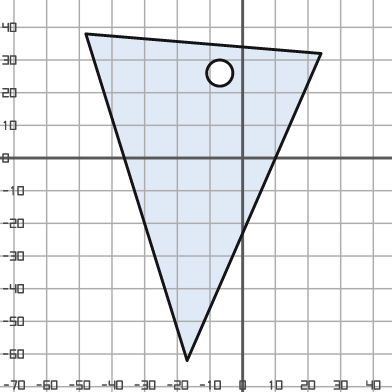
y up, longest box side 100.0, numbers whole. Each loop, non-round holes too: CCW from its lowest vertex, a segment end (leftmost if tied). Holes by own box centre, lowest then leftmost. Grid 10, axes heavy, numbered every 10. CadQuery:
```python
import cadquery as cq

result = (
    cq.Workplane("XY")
    .moveTo(-17.0, -62.0)
    .lineTo(24.0, 32.0)
    .lineTo(-48.0, 38.0)
    .close()
    .moveTo(-7.0, 26.0)
    .circle(4.0)
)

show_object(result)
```